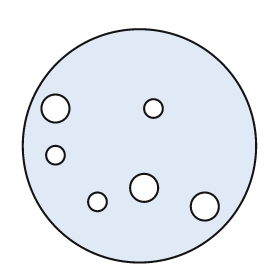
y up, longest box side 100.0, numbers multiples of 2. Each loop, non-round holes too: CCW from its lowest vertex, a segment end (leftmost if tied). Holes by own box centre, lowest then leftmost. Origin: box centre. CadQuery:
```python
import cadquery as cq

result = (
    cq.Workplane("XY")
    .moveTo(0.0, 0.0)
    .circle(50.0)
    .moveTo(28.0, -26.0)
    .circle(6.0)
    .moveTo(-18.0, -24.0)
    .circle(4.0)
    .moveTo(2.0, -18.0)
    .circle(6.0)
    .moveTo(-36.0, -4.0)
    .circle(4.0)
    .moveTo(-36.0, 16.0)
    .circle(6.0)
    .moveTo(6.0, 16.0)
    .circle(4.0)
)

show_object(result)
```